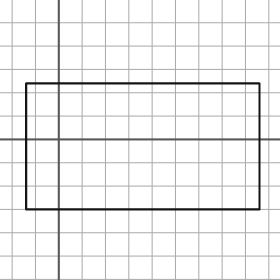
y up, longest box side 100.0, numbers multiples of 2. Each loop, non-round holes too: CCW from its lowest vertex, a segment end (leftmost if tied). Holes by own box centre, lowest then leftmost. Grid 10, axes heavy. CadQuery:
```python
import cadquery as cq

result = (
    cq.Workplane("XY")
    .moveTo(-14.0, -30.0)
    .lineTo(86.0, -30.0)
    .lineTo(86.0, 24.0)
    .lineTo(-14.0, 24.0)
    .close()
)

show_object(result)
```